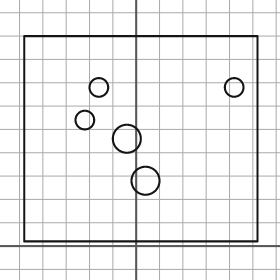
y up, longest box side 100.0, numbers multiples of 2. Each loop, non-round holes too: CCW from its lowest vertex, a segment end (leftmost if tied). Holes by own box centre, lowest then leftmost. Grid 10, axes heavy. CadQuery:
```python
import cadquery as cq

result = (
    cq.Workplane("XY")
    .moveTo(-48.0, 2.0)
    .lineTo(52.0, 2.0)
    .lineTo(52.0, 90.0)
    .lineTo(-48.0, 90.0)
    .close()
    .moveTo(4.0, 28.0)
    .circle(6.0)
    .moveTo(-4.0, 46.0)
    .circle(6.0)
    .moveTo(-22.0, 54.0)
    .circle(4.0)
    .moveTo(-16.0, 68.0)
    .circle(4.0)
    .moveTo(42.0, 68.0)
    .circle(4.0)
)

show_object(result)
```